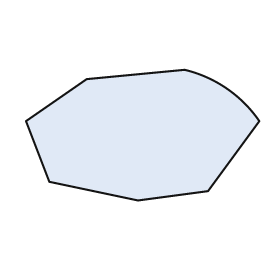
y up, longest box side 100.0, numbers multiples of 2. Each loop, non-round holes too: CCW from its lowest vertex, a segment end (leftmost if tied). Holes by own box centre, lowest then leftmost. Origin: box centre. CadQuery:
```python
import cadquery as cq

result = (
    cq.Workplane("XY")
    .moveTo(-2.0, -28.0)
    .lineTo(28.0, -24.0)
    .lineTo(50.0, 6.0)
    .threePointArc((36.0, 20.0), (18.0, 28.0))
    .lineTo(-24.0, 24.0)
    .lineTo(-50.0, 6.0)
    .lineTo(-40.0, -20.0)
    .close()
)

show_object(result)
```